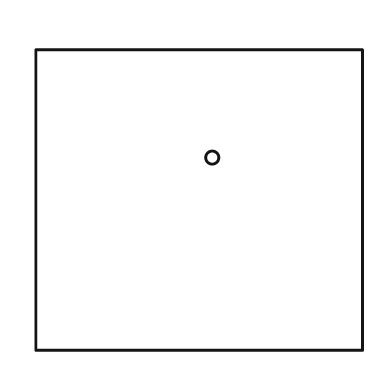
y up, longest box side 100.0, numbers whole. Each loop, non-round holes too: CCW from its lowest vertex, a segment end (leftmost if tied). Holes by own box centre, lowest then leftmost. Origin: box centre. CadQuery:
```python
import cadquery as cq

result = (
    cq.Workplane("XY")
    .moveTo(-50.0, -46.0)
    .lineTo(50.0, -46.0)
    .lineTo(50.0, 46.0)
    .lineTo(-50.0, 46.0)
    .close()
    .moveTo(4.0, 13.0)
    .circle(2.0)
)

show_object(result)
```